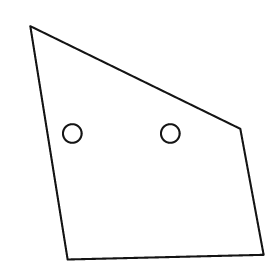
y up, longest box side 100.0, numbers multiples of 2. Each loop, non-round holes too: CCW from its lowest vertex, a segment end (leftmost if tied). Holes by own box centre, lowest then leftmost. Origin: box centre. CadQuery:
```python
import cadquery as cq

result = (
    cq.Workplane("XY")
    .moveTo(-34.0, -50.0)
    .lineTo(50.0, -48.0)
    .lineTo(40.0, 6.0)
    .lineTo(-50.0, 50.0)
    .close()
    .moveTo(-32.0, 4.0)
    .circle(4.0)
    .moveTo(10.0, 4.0)
    .circle(4.0)
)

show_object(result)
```